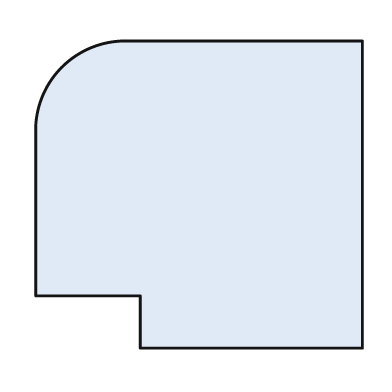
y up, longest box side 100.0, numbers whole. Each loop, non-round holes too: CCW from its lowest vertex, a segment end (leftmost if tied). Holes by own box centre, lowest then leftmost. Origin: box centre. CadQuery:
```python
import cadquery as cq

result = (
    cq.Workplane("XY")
    .moveTo(-18.0, -47.0)
    .lineTo(50.0, -47.0)
    .lineTo(50.0, 47.0)
    .lineTo(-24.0, 47.0)
    .threePointArc((-42.0, 39.0), (-50.0, 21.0))
    .lineTo(-50.0, -31.0)
    .lineTo(-18.0, -31.0)
    .close()
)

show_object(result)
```